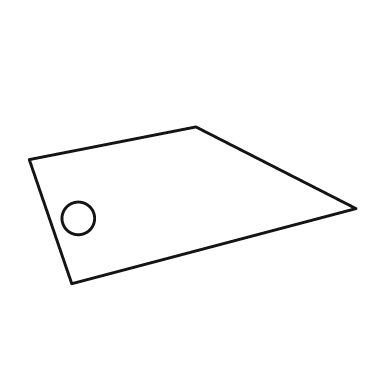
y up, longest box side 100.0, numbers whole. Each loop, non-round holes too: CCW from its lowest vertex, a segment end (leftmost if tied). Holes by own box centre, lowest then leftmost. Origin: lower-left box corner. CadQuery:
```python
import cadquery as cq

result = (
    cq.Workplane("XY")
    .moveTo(13.0, 0.0)
    .lineTo(100.0, 23.0)
    .lineTo(51.0, 48.0)
    .lineTo(0.0, 38.0)
    .close()
    .moveTo(15.0, 20.0)
    .circle(5.0)
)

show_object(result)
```